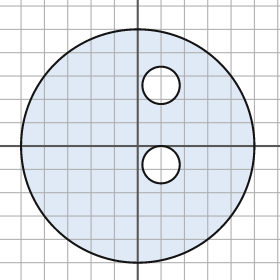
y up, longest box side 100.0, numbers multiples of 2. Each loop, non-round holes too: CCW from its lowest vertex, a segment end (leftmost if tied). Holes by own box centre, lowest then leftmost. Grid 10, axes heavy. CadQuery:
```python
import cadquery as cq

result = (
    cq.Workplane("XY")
    .moveTo(0.0, 0.0)
    .circle(50.0)
    .moveTo(10.0, -8.0)
    .circle(8.0)
    .moveTo(10.0, 26.0)
    .circle(8.0)
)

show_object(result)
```